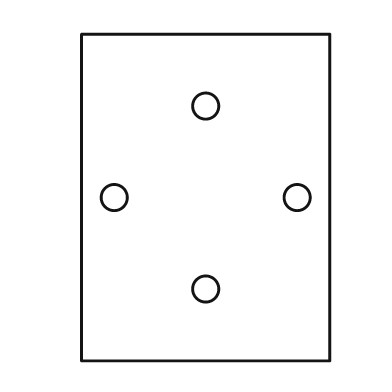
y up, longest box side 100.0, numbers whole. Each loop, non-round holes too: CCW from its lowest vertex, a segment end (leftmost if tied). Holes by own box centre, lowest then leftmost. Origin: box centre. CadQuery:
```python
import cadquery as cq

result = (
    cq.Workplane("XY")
    .moveTo(-38.0, -50.0)
    .lineTo(38.0, -50.0)
    .lineTo(38.0, 50.0)
    .lineTo(-38.0, 50.0)
    .close()
    .moveTo(0.0, -28.0)
    .circle(4.0)
    .moveTo(-28.0, 0.0)
    .circle(4.0)
    .moveTo(28.0, 0.0)
    .circle(4.0)
    .moveTo(0.0, 28.0)
    .circle(4.0)
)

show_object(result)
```